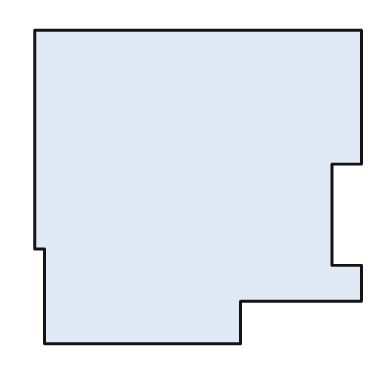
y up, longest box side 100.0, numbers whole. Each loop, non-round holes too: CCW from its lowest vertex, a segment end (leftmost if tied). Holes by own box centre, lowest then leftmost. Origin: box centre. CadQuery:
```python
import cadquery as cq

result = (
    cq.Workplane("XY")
    .moveTo(-47.0, -48.0)
    .lineTo(13.0, -48.0)
    .lineTo(13.0, -35.0)
    .lineTo(50.0, -35.0)
    .lineTo(50.0, -24.0)
    .lineTo(41.0, -24.0)
    .lineTo(41.0, 7.0)
    .lineTo(50.0, 7.0)
    .lineTo(50.0, 48.0)
    .lineTo(-50.0, 48.0)
    .lineTo(-50.0, -19.0)
    .lineTo(-47.0, -19.0)
    .close()
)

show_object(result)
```